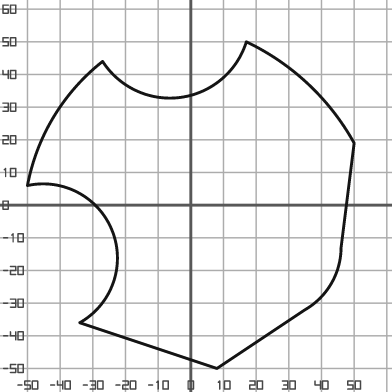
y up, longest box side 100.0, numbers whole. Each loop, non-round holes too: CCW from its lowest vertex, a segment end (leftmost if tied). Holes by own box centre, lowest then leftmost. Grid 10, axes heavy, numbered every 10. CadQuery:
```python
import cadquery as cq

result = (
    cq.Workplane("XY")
    .moveTo(8.0, -50.0)
    .lineTo(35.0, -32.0)
    .threePointArc((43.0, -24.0), (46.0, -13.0))
    .lineTo(50.0, 19.0)
    .threePointArc((36.0, 37.0), (17.0, 50.0))
    .threePointArc((-3.0, 33.0), (-27.0, 44.0))
    .threePointArc((-42.0, 27.0), (-50.0, 6.0))
    .threePointArc((-24.0, -8.0), (-34.0, -36.0))
    .close()
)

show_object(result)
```